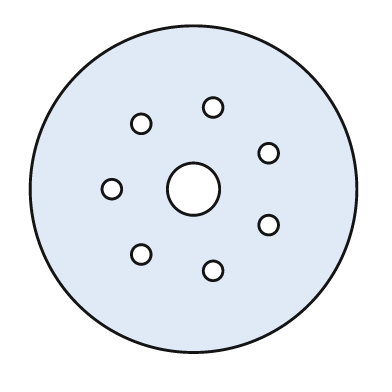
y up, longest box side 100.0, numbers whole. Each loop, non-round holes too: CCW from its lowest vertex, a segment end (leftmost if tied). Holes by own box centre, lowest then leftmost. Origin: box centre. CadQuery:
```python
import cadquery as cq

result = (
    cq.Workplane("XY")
    .moveTo(0.0, 0.0)
    .circle(50.0)
    .moveTo(6.0, -25.0)
    .circle(3.0)
    .moveTo(-16.0, -20.0)
    .circle(3.0)
    .moveTo(23.0, -11.0)
    .circle(3.0)
    .moveTo(-25.0, 0.0)
    .circle(3.0)
    .moveTo(0.0, 0.0)
    .circle(8.0)
    .moveTo(23.0, 11.0)
    .circle(3.0)
    .moveTo(-16.0, 20.0)
    .circle(3.0)
    .moveTo(6.0, 25.0)
    .circle(3.0)
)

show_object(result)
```